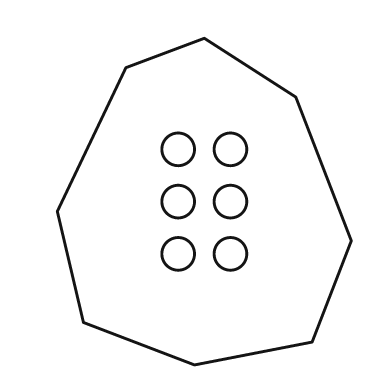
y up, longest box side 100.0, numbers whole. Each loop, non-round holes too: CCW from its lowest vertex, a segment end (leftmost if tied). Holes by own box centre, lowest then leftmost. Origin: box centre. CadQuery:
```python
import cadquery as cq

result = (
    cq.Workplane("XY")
    .moveTo(-3.0, -50.0)
    .lineTo(33.0, -43.0)
    .lineTo(45.0, -12.0)
    .lineTo(28.0, 32.0)
    .lineTo(0.0, 50.0)
    .lineTo(-24.0, 41.0)
    .lineTo(-45.0, -3.0)
    .lineTo(-37.0, -37.0)
    .close()
    .moveTo(-8.0, -16.0)
    .circle(5.0)
    .moveTo(8.0, -16.0)
    .circle(5.0)
    .moveTo(-8.0, 0.0)
    .circle(5.0)
    .moveTo(8.0, 0.0)
    .circle(5.0)
    .moveTo(-8.0, 16.0)
    .circle(5.0)
    .moveTo(8.0, 16.0)
    .circle(5.0)
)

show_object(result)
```